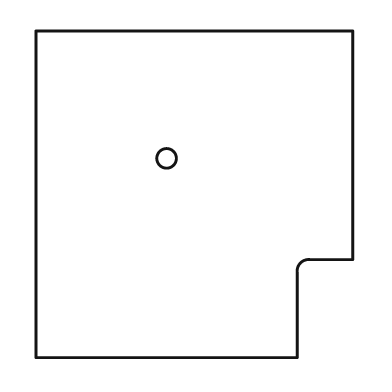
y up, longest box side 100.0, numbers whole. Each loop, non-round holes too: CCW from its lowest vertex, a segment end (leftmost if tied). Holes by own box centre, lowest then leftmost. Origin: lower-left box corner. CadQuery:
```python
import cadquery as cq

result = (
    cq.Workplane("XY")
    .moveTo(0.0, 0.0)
    .lineTo(80.0, 0.0)
    .lineTo(80.0, 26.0)
    .threePointArc((81.0, 29.0), (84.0, 30.0))
    .lineTo(97.0, 30.0)
    .lineTo(97.0, 100.0)
    .lineTo(0.0, 100.0)
    .close()
    .moveTo(40.0, 61.0)
    .circle(3.0)
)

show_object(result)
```